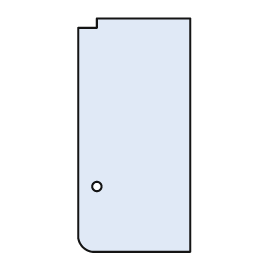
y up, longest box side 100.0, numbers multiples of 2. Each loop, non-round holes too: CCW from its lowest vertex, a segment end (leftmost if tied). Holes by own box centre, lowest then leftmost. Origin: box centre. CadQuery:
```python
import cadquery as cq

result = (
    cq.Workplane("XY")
    .moveTo(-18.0, -50.0)
    .lineTo(24.0, -50.0)
    .lineTo(24.0, 50.0)
    .lineTo(-16.0, 50.0)
    .lineTo(-16.0, 46.0)
    .lineTo(-24.0, 46.0)
    .lineTo(-24.0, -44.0)
    .threePointArc((-22.0, -48.0), (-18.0, -50.0))
    .close()
    .moveTo(-16.0, -22.0)
    .circle(2.0)
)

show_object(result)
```